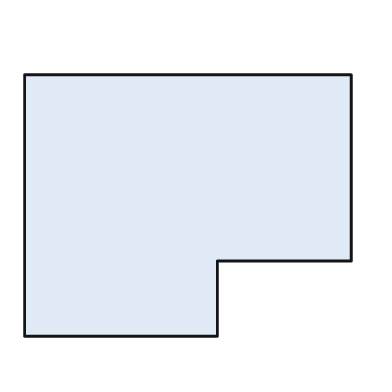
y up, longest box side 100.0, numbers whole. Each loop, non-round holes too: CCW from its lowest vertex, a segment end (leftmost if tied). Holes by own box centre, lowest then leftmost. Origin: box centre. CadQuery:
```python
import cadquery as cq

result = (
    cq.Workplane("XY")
    .moveTo(-50.0, -40.0)
    .lineTo(9.0, -40.0)
    .lineTo(9.0, -17.0)
    .lineTo(50.0, -17.0)
    .lineTo(50.0, 40.0)
    .lineTo(-50.0, 40.0)
    .close()
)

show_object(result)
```